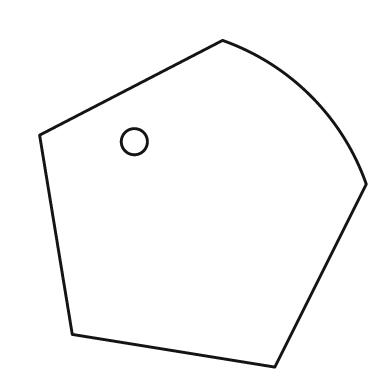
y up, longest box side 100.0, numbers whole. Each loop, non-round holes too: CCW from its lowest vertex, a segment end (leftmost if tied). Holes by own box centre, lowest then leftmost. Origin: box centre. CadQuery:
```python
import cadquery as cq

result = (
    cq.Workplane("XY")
    .moveTo(22.0, -50.0)
    .lineTo(50.0, 6.0)
    .threePointArc((33.0, 33.0), (6.0, 50.0))
    .lineTo(-50.0, 21.0)
    .lineTo(-40.0, -40.0)
    .close()
    .moveTo(-21.0, 19.0)
    .circle(4.0)
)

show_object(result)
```